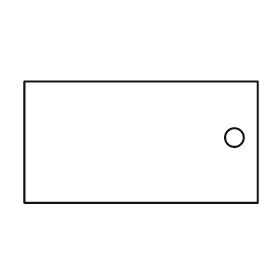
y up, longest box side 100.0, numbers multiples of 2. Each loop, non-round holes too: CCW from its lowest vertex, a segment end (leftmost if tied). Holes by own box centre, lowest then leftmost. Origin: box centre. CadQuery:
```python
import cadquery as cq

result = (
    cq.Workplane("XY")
    .moveTo(-50.0, -26.0)
    .lineTo(50.0, -26.0)
    .lineTo(50.0, 26.0)
    .lineTo(-50.0, 26.0)
    .close()
    .moveTo(40.0, 2.0)
    .circle(4.0)
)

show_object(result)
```